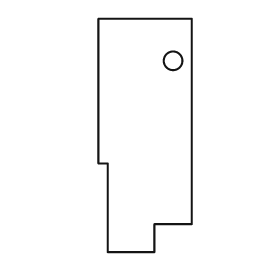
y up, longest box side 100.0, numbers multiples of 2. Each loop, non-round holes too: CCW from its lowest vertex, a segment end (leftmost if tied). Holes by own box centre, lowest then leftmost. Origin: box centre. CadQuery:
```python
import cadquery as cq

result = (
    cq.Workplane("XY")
    .moveTo(-16.0, -50.0)
    .lineTo(4.0, -50.0)
    .lineTo(4.0, -38.0)
    .lineTo(20.0, -38.0)
    .lineTo(20.0, 50.0)
    .lineTo(-20.0, 50.0)
    .lineTo(-20.0, -12.0)
    .lineTo(-16.0, -12.0)
    .close()
    .moveTo(12.0, 32.0)
    .circle(4.0)
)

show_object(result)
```